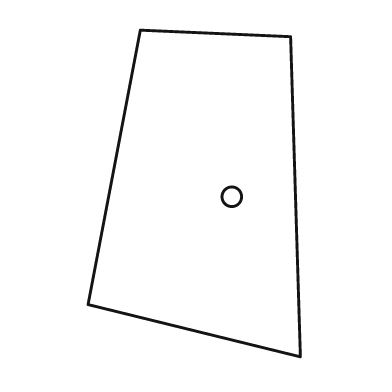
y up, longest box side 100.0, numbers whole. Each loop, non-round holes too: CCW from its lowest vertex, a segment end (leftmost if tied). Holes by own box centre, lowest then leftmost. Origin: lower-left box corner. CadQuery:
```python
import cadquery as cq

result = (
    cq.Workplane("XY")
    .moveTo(65.0, 0.0)
    .lineTo(62.0, 98.0)
    .lineTo(16.0, 100.0)
    .lineTo(0.0, 16.0)
    .close()
    .moveTo(44.0, 49.0)
    .circle(3.0)
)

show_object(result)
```